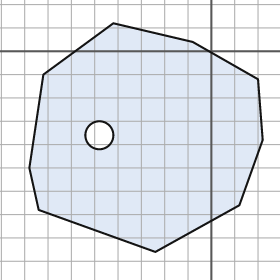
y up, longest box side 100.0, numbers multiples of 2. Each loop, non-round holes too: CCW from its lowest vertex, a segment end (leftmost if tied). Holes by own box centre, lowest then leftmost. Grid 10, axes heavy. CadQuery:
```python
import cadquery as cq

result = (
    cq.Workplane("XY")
    .moveTo(-24.0, -86.0)
    .lineTo(12.0, -66.0)
    .lineTo(22.0, -38.0)
    .lineTo(20.0, -12.0)
    .lineTo(-8.0, 4.0)
    .lineTo(-42.0, 12.0)
    .lineTo(-72.0, -10.0)
    .lineTo(-78.0, -50.0)
    .lineTo(-74.0, -68.0)
    .close()
    .moveTo(-48.0, -36.0)
    .circle(6.0)
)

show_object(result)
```